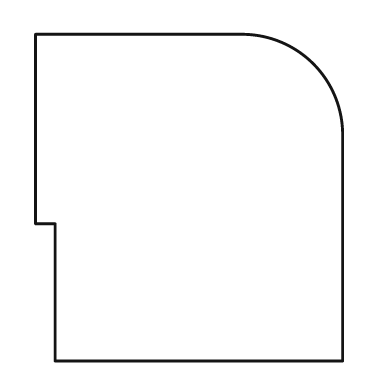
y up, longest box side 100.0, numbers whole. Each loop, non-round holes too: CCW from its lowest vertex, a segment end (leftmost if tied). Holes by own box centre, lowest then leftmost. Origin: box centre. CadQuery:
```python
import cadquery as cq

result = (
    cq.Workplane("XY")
    .moveTo(-41.0, -50.0)
    .lineTo(47.0, -50.0)
    .lineTo(47.0, 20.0)
    .threePointArc((38.0, 41.0), (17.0, 50.0))
    .lineTo(-47.0, 50.0)
    .lineTo(-47.0, -8.0)
    .lineTo(-41.0, -8.0)
    .close()
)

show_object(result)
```